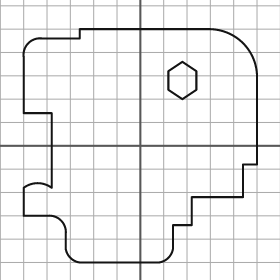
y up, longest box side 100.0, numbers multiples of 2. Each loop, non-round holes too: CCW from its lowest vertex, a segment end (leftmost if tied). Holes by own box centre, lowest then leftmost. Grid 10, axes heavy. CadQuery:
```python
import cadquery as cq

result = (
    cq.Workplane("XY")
    .moveTo(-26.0, -50.0)
    .lineTo(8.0, -50.0)
    .threePointArc((12.0, -48.0), (14.0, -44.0))
    .lineTo(14.0, -34.0)
    .lineTo(22.0, -34.0)
    .lineTo(22.0, -22.0)
    .lineTo(44.0, -22.0)
    .lineTo(44.0, -8.0)
    .lineTo(50.0, -8.0)
    .lineTo(50.0, 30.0)
    .threePointArc((44.0, 44.0), (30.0, 50.0))
    .lineTo(-26.0, 50.0)
    .lineTo(-26.0, 46.0)
    .lineTo(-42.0, 46.0)
    .threePointArc((-48.0, 44.0), (-50.0, 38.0))
    .lineTo(-50.0, 14.0)
    .lineTo(-38.0, 14.0)
    .lineTo(-38.0, -18.0)
    .threePointArc((-44.0, -16.0), (-50.0, -18.0))
    .lineTo(-50.0, -30.0)
    .lineTo(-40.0, -30.0)
    .threePointArc((-34.0, -32.0), (-32.0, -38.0))
    .lineTo(-32.0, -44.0)
    .threePointArc((-30.0, -48.0), (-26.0, -50.0))
    .close()
    .moveTo(18.0, 20.0)
    .lineTo(24.0, 24.0)
    .lineTo(24.0, 32.0)
    .lineTo(18.0, 36.0)
    .lineTo(12.0, 32.0)
    .lineTo(12.0, 24.0)
    .close()
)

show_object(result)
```